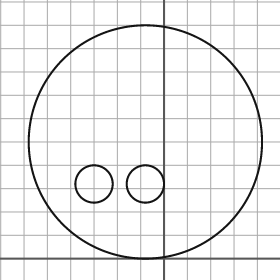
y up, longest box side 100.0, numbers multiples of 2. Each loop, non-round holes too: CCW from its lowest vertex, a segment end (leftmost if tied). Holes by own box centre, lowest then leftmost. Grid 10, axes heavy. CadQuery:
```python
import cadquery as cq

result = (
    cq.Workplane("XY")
    .moveTo(-8.0, 50.0)
    .circle(50.0)
    .moveTo(-30.0, 32.0)
    .circle(8.0)
    .moveTo(-8.0, 32.0)
    .circle(8.0)
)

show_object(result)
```